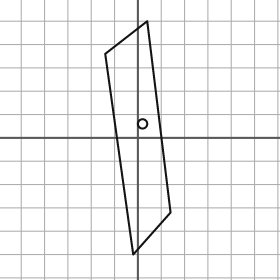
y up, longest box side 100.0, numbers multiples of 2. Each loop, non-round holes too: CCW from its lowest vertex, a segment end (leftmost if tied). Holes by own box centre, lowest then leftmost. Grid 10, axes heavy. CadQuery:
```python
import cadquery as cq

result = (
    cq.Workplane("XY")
    .moveTo(-2.0, -50.0)
    .lineTo(14.0, -32.0)
    .lineTo(4.0, 50.0)
    .lineTo(-14.0, 36.0)
    .close()
    .moveTo(2.0, 6.0)
    .circle(2.0)
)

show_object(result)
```